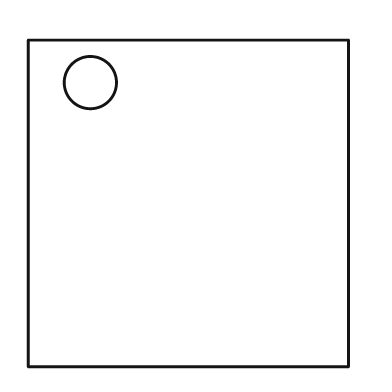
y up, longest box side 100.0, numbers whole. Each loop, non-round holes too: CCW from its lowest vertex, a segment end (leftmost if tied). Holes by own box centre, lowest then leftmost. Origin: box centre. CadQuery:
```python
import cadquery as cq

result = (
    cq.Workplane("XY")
    .moveTo(-49.0, -50.0)
    .lineTo(49.0, -50.0)
    .lineTo(49.0, 50.0)
    .lineTo(-49.0, 50.0)
    .close()
    .moveTo(-30.0, 37.0)
    .circle(8.0)
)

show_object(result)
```